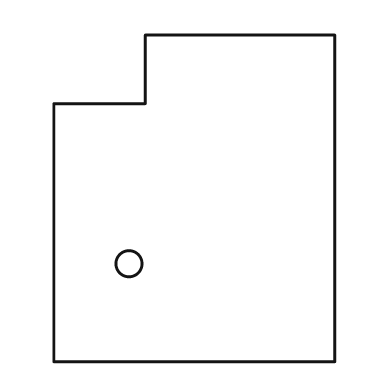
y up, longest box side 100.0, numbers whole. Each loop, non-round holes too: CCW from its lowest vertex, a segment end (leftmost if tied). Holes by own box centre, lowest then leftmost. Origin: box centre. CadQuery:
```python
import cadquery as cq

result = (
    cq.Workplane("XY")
    .moveTo(-43.0, -50.0)
    .lineTo(43.0, -50.0)
    .lineTo(43.0, 50.0)
    .lineTo(-15.0, 50.0)
    .lineTo(-15.0, 29.0)
    .lineTo(-43.0, 29.0)
    .close()
    .moveTo(-20.0, -20.0)
    .circle(4.0)
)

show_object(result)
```